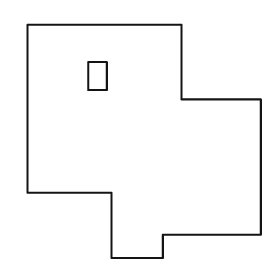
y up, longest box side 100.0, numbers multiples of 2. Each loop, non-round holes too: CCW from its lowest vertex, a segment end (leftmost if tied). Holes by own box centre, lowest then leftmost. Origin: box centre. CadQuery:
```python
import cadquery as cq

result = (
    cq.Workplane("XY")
    .moveTo(-14.0, -50.0)
    .lineTo(8.0, -50.0)
    .lineTo(8.0, -40.0)
    .lineTo(50.0, -40.0)
    .lineTo(50.0, 18.0)
    .lineTo(16.0, 18.0)
    .lineTo(16.0, 50.0)
    .lineTo(-50.0, 50.0)
    .lineTo(-50.0, -22.0)
    .lineTo(-14.0, -22.0)
    .close()
    .moveTo(-24.0, 22.0)
    .lineTo(-16.0, 22.0)
    .lineTo(-16.0, 34.0)
    .lineTo(-24.0, 34.0)
    .close()
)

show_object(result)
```